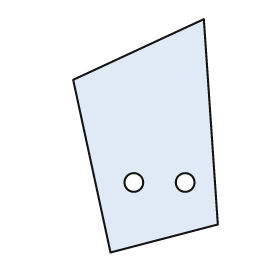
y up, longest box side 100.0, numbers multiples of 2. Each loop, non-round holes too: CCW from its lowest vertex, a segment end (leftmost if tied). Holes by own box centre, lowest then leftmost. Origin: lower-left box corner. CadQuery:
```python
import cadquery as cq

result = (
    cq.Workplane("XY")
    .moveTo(16.0, 0.0)
    .lineTo(62.0, 12.0)
    .lineTo(56.0, 100.0)
    .lineTo(0.0, 74.0)
    .close()
    .moveTo(26.0, 30.0)
    .circle(4.0)
    .moveTo(48.0, 30.0)
    .circle(4.0)
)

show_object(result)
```